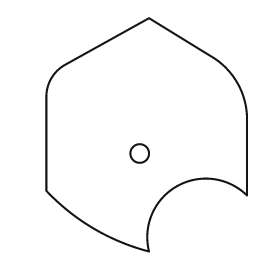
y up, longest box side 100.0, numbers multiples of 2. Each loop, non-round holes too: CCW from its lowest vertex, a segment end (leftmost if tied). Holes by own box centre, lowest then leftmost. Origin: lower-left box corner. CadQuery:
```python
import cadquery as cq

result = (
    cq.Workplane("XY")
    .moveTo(44.0, 0.0)
    .threePointArc((56.0, 28.0), (86.0, 24.0))
    .lineTo(86.0, 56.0)
    .threePointArc((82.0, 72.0), (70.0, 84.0))
    .lineTo(44.0, 100.0)
    .lineTo(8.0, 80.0)
    .threePointArc((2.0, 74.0), (0.0, 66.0))
    .lineTo(0.0, 26.0)
    .threePointArc((20.0, 10.0), (44.0, 0.0))
    .close()
    .moveTo(40.0, 42.0)
    .circle(4.0)
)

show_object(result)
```